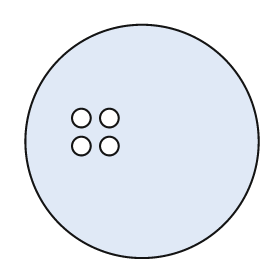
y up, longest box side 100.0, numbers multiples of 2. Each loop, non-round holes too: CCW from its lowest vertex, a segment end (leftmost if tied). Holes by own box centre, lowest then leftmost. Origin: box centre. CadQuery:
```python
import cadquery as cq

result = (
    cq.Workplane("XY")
    .moveTo(0.0, 0.0)
    .circle(50.0)
    .moveTo(-26.0, -2.0)
    .circle(4.0)
    .moveTo(-14.0, -2.0)
    .circle(4.0)
    .moveTo(-26.0, 10.0)
    .circle(4.0)
    .moveTo(-14.0, 10.0)
    .circle(4.0)
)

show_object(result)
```